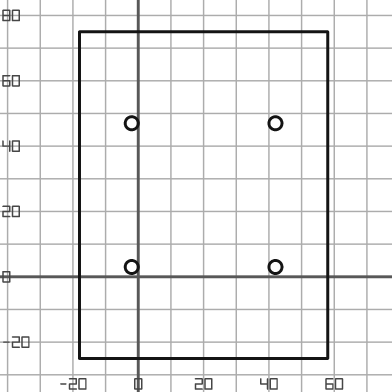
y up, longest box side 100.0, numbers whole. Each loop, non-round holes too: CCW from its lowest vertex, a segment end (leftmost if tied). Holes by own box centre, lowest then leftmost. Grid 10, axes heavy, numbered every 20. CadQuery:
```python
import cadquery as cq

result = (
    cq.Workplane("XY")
    .moveTo(-18.0, -25.0)
    .lineTo(58.0, -25.0)
    .lineTo(58.0, 75.0)
    .lineTo(-18.0, 75.0)
    .close()
    .moveTo(-2.0, 3.0)
    .circle(2.0)
    .moveTo(42.0, 3.0)
    .circle(2.0)
    .moveTo(-2.0, 47.0)
    .circle(2.0)
    .moveTo(42.0, 47.0)
    .circle(2.0)
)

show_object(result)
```